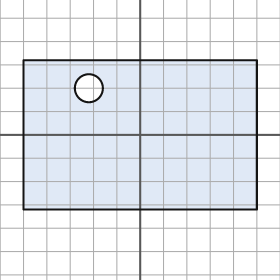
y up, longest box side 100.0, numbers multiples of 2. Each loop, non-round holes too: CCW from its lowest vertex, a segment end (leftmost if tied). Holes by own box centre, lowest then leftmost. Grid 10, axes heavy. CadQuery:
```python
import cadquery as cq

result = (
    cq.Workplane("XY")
    .moveTo(-50.0, -32.0)
    .lineTo(50.0, -32.0)
    .lineTo(50.0, 32.0)
    .lineTo(-50.0, 32.0)
    .close()
    .moveTo(-22.0, 20.0)
    .circle(6.0)
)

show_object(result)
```